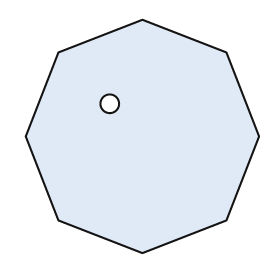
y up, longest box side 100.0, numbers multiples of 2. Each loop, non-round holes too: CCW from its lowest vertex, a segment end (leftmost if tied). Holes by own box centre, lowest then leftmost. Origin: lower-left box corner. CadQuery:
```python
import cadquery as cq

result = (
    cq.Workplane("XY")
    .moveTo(50.0, 0.0)
    .lineTo(86.0, 14.0)
    .lineTo(100.0, 50.0)
    .lineTo(86.0, 86.0)
    .lineTo(50.0, 100.0)
    .lineTo(14.0, 86.0)
    .lineTo(0.0, 50.0)
    .lineTo(14.0, 14.0)
    .close()
    .moveTo(36.0, 64.0)
    .circle(4.0)
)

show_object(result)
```